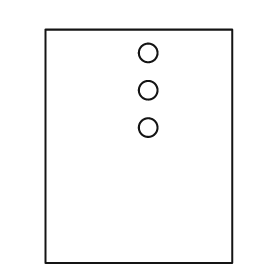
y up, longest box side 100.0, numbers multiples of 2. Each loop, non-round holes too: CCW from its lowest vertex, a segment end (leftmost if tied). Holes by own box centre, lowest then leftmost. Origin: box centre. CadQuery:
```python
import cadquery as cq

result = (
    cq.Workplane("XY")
    .moveTo(-40.0, -50.0)
    .lineTo(40.0, -50.0)
    .lineTo(40.0, 50.0)
    .lineTo(-40.0, 50.0)
    .close()
    .moveTo(4.0, 8.0)
    .circle(4.0)
    .moveTo(4.0, 24.0)
    .circle(4.0)
    .moveTo(4.0, 40.0)
    .circle(4.0)
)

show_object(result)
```